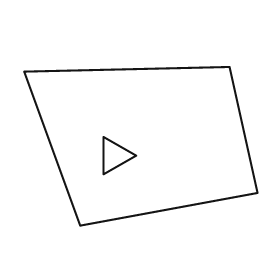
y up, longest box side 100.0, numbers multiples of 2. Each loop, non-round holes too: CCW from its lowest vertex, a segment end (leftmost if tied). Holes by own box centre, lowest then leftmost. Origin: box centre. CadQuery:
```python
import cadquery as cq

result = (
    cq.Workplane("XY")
    .moveTo(-26.0, -34.0)
    .lineTo(50.0, -20.0)
    .lineTo(38.0, 34.0)
    .lineTo(-50.0, 32.0)
    .close()
    .moveTo(-16.0, -12.0)
    .lineTo(-2.0, -4.0)
    .lineTo(-16.0, 4.0)
    .close()
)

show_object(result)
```